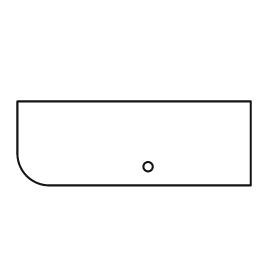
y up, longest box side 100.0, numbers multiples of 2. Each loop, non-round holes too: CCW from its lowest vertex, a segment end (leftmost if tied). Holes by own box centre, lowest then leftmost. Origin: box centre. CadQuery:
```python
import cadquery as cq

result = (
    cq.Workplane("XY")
    .moveTo(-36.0, -18.0)
    .lineTo(50.0, -18.0)
    .lineTo(50.0, 18.0)
    .lineTo(-50.0, 18.0)
    .lineTo(-50.0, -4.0)
    .threePointArc((-46.0, -14.0), (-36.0, -18.0))
    .close()
    .moveTo(6.0, -10.0)
    .circle(2.0)
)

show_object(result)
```